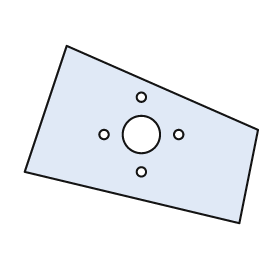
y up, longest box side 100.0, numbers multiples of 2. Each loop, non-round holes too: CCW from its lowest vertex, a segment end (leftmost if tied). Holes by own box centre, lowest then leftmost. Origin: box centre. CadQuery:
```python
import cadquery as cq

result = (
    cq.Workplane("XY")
    .moveTo(42.0, -38.0)
    .lineTo(50.0, 2.0)
    .lineTo(-32.0, 38.0)
    .lineTo(-50.0, -16.0)
    .close()
    .moveTo(0.0, -16.0)
    .circle(2.0)
    .moveTo(-16.0, 0.0)
    .circle(2.0)
    .moveTo(0.0, 0.0)
    .circle(8.0)
    .moveTo(16.0, 0.0)
    .circle(2.0)
    .moveTo(0.0, 16.0)
    .circle(2.0)
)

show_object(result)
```